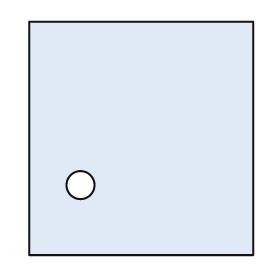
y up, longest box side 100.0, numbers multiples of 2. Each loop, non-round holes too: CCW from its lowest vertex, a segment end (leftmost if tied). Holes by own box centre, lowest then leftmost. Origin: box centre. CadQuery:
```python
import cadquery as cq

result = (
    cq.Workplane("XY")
    .moveTo(-48.0, -50.0)
    .lineTo(48.0, -50.0)
    .lineTo(48.0, 50.0)
    .lineTo(-48.0, 50.0)
    .close()
    .moveTo(-26.0, -20.0)
    .circle(6.0)
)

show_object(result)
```